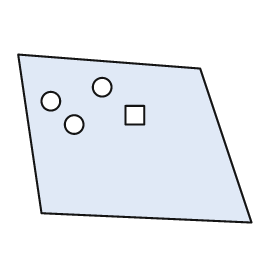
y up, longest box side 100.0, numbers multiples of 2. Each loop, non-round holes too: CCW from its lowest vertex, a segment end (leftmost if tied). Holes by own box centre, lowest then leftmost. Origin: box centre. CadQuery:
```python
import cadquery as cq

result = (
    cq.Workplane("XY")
    .moveTo(50.0, -36.0)
    .lineTo(28.0, 30.0)
    .lineTo(-50.0, 36.0)
    .lineTo(-40.0, -32.0)
    .close()
    .moveTo(-26.0, 6.0)
    .circle(4.0)
    .moveTo(-4.0, 6.0)
    .lineTo(4.0, 6.0)
    .lineTo(4.0, 14.0)
    .lineTo(-4.0, 14.0)
    .close()
    .moveTo(-36.0, 16.0)
    .circle(4.0)
    .moveTo(-14.0, 22.0)
    .circle(4.0)
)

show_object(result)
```